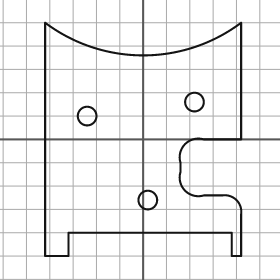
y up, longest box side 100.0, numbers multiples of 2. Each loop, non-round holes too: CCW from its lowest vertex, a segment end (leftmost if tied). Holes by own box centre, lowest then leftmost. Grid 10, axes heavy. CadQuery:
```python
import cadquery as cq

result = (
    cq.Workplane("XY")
    .moveTo(-42.0, -50.0)
    .lineTo(-32.0, -50.0)
    .lineTo(-32.0, -40.0)
    .lineTo(38.0, -40.0)
    .lineTo(38.0, -50.0)
    .lineTo(42.0, -50.0)
    .lineTo(42.0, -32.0)
    .threePointArc((40.0, -26.0), (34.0, -24.0))
    .lineTo(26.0, -24.0)
    .threePointArc((18.0, -22.0), (16.0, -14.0))
    .lineTo(16.0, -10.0)
    .threePointArc((18.0, -2.0), (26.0, 0.0))
    .lineTo(42.0, 0.0)
    .lineTo(42.0, 50.0)
    .threePointArc((0.0, 36.0), (-42.0, 50.0))
    .close()
    .moveTo(2.0, -26.0)
    .circle(4.0)
    .moveTo(-24.0, 10.0)
    .circle(4.0)
    .moveTo(22.0, 16.0)
    .circle(4.0)
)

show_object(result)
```